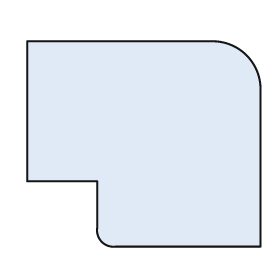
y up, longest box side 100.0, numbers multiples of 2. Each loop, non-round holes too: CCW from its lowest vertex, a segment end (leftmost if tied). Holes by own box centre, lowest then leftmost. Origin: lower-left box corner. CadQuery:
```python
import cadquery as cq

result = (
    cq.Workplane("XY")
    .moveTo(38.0, 0.0)
    .lineTo(100.0, 0.0)
    .lineTo(100.0, 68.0)
    .threePointArc((94.0, 82.0), (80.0, 88.0))
    .lineTo(0.0, 88.0)
    .lineTo(0.0, 28.0)
    .lineTo(30.0, 28.0)
    .lineTo(30.0, 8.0)
    .threePointArc((32.0, 2.0), (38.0, 0.0))
    .close()
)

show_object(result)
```